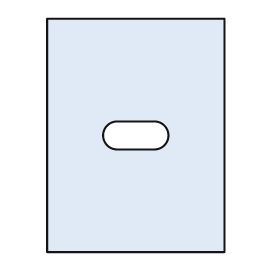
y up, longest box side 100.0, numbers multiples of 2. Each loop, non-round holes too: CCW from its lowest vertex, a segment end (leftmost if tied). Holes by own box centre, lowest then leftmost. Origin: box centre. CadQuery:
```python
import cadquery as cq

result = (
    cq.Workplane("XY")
    .moveTo(-38.0, -50.0)
    .lineTo(38.0, -50.0)
    .lineTo(38.0, 50.0)
    .lineTo(-38.0, 50.0)
    .close()
    .moveTo(-8.0, -6.0)
    .lineTo(8.0, -6.0)
    .threePointArc((14.0, 0.0), (8.0, 6.0))
    .lineTo(-8.0, 6.0)
    .threePointArc((-14.0, 0.0), (-8.0, -6.0))
    .close()
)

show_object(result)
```